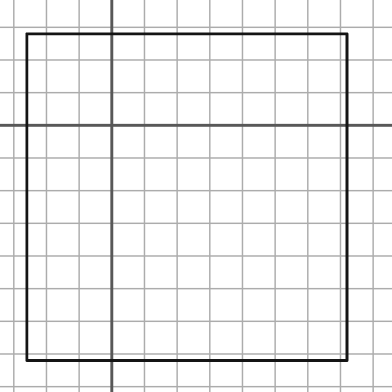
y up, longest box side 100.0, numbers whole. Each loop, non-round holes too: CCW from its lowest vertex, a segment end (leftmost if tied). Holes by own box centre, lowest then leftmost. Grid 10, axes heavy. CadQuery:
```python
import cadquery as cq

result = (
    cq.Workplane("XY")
    .moveTo(-26.0, -72.0)
    .lineTo(72.0, -72.0)
    .lineTo(72.0, 28.0)
    .lineTo(-26.0, 28.0)
    .close()
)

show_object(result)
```